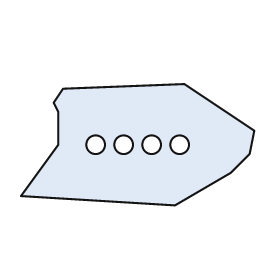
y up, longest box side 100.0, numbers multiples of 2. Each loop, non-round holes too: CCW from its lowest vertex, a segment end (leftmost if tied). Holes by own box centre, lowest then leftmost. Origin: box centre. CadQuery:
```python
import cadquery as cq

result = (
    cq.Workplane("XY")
    .moveTo(16.0, -26.0)
    .lineTo(40.0, -12.0)
    .lineTo(48.0, -4.0)
    .lineTo(50.0, 6.0)
    .lineTo(20.0, 26.0)
    .lineTo(-32.0, 24.0)
    .lineTo(-36.0, 18.0)
    .lineTo(-34.0, 14.0)
    .lineTo(-34.0, 0.0)
    .lineTo(-50.0, -22.0)
    .close()
    .moveTo(-18.0, 0.0)
    .circle(4.0)
    .moveTo(-6.0, 0.0)
    .circle(4.0)
    .moveTo(6.0, 0.0)
    .circle(4.0)
    .moveTo(18.0, 0.0)
    .circle(4.0)
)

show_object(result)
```